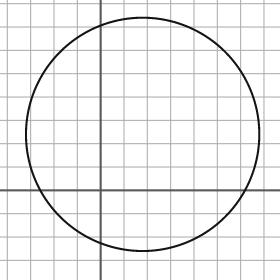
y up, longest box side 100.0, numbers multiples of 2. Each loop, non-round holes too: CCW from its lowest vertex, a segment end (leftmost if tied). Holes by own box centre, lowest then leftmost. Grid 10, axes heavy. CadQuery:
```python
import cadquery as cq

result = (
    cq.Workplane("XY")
    .moveTo(18.0, 24.0)
    .circle(50.0)
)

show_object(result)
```